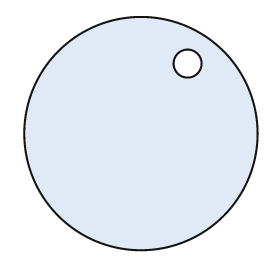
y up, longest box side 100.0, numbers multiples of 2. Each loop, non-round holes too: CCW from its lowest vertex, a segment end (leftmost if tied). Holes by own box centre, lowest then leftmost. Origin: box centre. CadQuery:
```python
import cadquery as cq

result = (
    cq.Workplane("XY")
    .moveTo(0.0, 0.0)
    .circle(50.0)
    .moveTo(20.0, 30.0)
    .circle(6.0)
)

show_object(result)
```